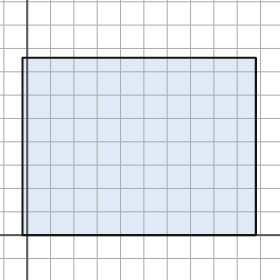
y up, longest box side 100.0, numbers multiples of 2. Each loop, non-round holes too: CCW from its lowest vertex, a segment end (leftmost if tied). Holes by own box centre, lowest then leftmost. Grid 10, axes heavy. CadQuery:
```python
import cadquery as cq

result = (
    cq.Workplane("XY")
    .moveTo(-2.0, 0.0)
    .lineTo(98.0, 0.0)
    .lineTo(98.0, 76.0)
    .lineTo(-2.0, 76.0)
    .close()
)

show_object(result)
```